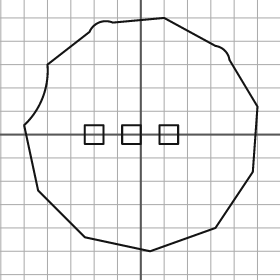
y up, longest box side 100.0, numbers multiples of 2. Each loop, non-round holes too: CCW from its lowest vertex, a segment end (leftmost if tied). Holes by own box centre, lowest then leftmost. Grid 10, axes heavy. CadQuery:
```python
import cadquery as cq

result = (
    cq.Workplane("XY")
    .moveTo(4.0, -50.0)
    .lineTo(32.0, -40.0)
    .lineTo(48.0, -16.0)
    .lineTo(50.0, 12.0)
    .lineTo(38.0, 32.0)
    .threePointArc((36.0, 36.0), (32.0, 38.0))
    .lineTo(10.0, 50.0)
    .lineTo(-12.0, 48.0)
    .threePointArc((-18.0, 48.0), (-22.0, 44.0))
    .lineTo(-40.0, 30.0)
    .threePointArc((-42.0, 16.0), (-50.0, 4.0))
    .lineTo(-44.0, -24.0)
    .lineTo(-24.0, -44.0)
    .close()
    .moveTo(-24.0, -4.0)
    .lineTo(-16.0, -4.0)
    .lineTo(-16.0, 4.0)
    .lineTo(-24.0, 4.0)
    .close()
    .moveTo(-8.0, -4.0)
    .lineTo(0.0, -4.0)
    .lineTo(0.0, 4.0)
    .lineTo(-8.0, 4.0)
    .close()
    .moveTo(8.0, -4.0)
    .lineTo(16.0, -4.0)
    .lineTo(16.0, 4.0)
    .lineTo(8.0, 4.0)
    .close()
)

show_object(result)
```